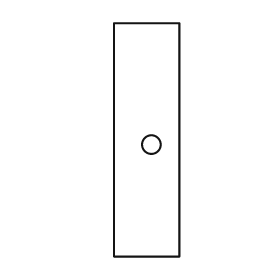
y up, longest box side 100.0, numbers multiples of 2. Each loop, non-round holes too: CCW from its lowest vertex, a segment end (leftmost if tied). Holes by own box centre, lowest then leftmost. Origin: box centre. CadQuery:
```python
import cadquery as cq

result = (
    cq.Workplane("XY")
    .moveTo(-14.0, -50.0)
    .lineTo(14.0, -50.0)
    .lineTo(14.0, 50.0)
    .lineTo(-14.0, 50.0)
    .close()
    .moveTo(2.0, -2.0)
    .circle(4.0)
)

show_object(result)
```